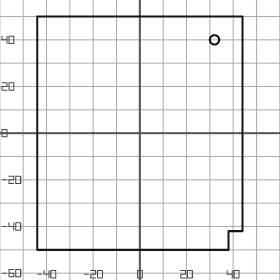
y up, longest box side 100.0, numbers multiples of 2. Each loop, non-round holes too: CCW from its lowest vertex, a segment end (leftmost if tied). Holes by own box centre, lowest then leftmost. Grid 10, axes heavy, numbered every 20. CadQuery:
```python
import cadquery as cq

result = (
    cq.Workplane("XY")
    .moveTo(-44.0, -50.0)
    .lineTo(38.0, -50.0)
    .lineTo(38.0, -42.0)
    .lineTo(44.0, -42.0)
    .lineTo(44.0, 50.0)
    .lineTo(-44.0, 50.0)
    .close()
    .moveTo(32.0, 40.0)
    .circle(2.0)
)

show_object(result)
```